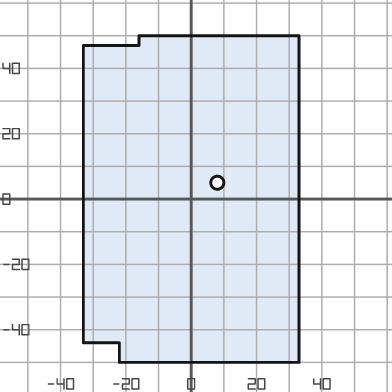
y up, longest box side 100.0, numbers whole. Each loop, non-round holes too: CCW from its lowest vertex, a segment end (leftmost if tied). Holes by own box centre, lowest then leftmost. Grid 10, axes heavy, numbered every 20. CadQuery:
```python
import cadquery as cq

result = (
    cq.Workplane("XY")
    .moveTo(-22.0, -50.0)
    .lineTo(33.0, -50.0)
    .lineTo(33.0, 50.0)
    .lineTo(-16.0, 50.0)
    .lineTo(-16.0, 47.0)
    .lineTo(-33.0, 47.0)
    .lineTo(-33.0, -44.0)
    .lineTo(-22.0, -44.0)
    .close()
    .moveTo(8.0, 5.0)
    .circle(2.0)
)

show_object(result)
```